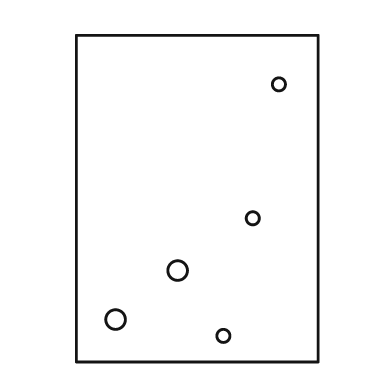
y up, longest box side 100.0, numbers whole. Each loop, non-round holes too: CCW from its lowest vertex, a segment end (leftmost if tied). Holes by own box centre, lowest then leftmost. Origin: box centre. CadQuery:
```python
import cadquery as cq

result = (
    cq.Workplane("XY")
    .moveTo(-37.0, -50.0)
    .lineTo(37.0, -50.0)
    .lineTo(37.0, 50.0)
    .lineTo(-37.0, 50.0)
    .close()
    .moveTo(8.0, -42.0)
    .circle(2.0)
    .moveTo(-25.0, -37.0)
    .circle(3.0)
    .moveTo(-6.0, -22.0)
    .circle(3.0)
    .moveTo(17.0, -6.0)
    .circle(2.0)
    .moveTo(25.0, 35.0)
    .circle(2.0)
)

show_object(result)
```